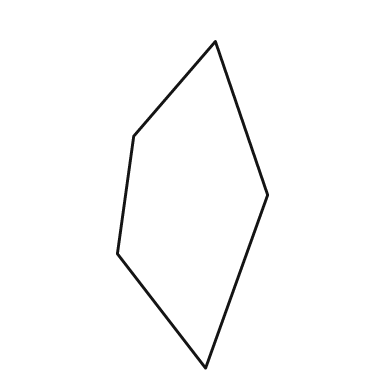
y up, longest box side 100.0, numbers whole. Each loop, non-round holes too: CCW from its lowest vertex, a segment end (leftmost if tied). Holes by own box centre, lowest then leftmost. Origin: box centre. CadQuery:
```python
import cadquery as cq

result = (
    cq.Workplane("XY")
    .moveTo(4.0, -50.0)
    .lineTo(23.0, 3.0)
    .lineTo(7.0, 50.0)
    .lineTo(-18.0, 21.0)
    .lineTo(-23.0, -15.0)
    .close()
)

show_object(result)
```